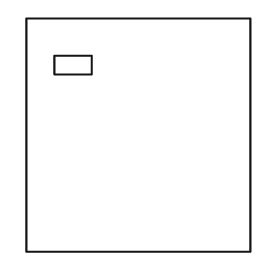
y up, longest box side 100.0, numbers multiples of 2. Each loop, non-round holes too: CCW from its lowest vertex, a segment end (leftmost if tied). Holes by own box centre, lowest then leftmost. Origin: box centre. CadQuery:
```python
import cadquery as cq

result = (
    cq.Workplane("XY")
    .moveTo(-48.0, -50.0)
    .lineTo(48.0, -50.0)
    .lineTo(48.0, 50.0)
    .lineTo(-48.0, 50.0)
    .close()
    .moveTo(-36.0, 26.0)
    .lineTo(-20.0, 26.0)
    .lineTo(-20.0, 34.0)
    .lineTo(-36.0, 34.0)
    .close()
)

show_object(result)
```